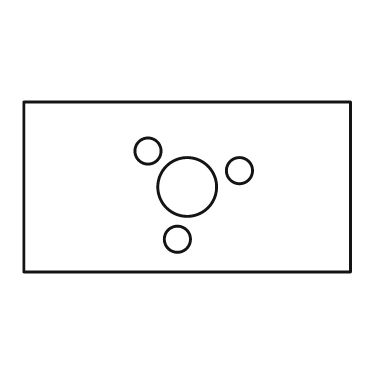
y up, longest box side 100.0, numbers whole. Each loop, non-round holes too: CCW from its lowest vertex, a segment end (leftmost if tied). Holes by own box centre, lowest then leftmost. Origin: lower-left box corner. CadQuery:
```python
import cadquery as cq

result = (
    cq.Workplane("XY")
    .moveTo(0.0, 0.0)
    .lineTo(100.0, 0.0)
    .lineTo(100.0, 52.0)
    .lineTo(0.0, 52.0)
    .close()
    .moveTo(47.0, 10.0)
    .circle(4.0)
    .moveTo(50.0, 26.0)
    .circle(9.0)
    .moveTo(66.0, 31.0)
    .circle(4.0)
    .moveTo(38.0, 37.0)
    .circle(4.0)
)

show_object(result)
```